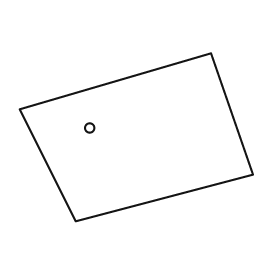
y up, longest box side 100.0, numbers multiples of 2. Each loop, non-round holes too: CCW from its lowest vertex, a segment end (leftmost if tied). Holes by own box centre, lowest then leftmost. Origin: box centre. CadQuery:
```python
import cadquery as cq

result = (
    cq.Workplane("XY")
    .moveTo(-26.0, -36.0)
    .lineTo(50.0, -16.0)
    .lineTo(32.0, 36.0)
    .lineTo(-50.0, 12.0)
    .close()
    .moveTo(-20.0, 4.0)
    .circle(2.0)
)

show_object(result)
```